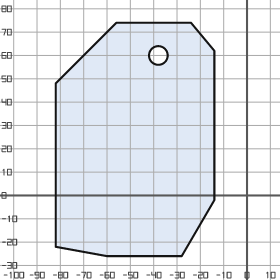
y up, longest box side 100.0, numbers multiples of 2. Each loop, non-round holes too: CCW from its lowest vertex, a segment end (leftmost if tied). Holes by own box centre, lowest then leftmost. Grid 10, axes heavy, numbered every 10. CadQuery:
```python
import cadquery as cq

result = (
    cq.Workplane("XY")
    .moveTo(-60.0, -26.0)
    .lineTo(-28.0, -26.0)
    .lineTo(-14.0, -2.0)
    .lineTo(-14.0, 62.0)
    .lineTo(-24.0, 74.0)
    .lineTo(-56.0, 74.0)
    .lineTo(-82.0, 48.0)
    .lineTo(-82.0, -22.0)
    .close()
    .moveTo(-38.0, 60.0)
    .circle(4.0)
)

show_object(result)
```